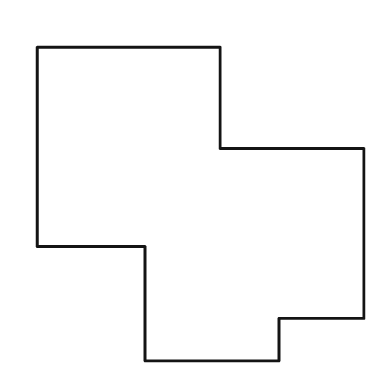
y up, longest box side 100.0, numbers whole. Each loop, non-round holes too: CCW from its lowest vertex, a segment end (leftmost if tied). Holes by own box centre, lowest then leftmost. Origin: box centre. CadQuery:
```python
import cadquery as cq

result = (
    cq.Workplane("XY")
    .moveTo(-17.0, -48.0)
    .lineTo(24.0, -48.0)
    .lineTo(24.0, -35.0)
    .lineTo(50.0, -35.0)
    .lineTo(50.0, 17.0)
    .lineTo(6.0, 17.0)
    .lineTo(6.0, 48.0)
    .lineTo(-50.0, 48.0)
    .lineTo(-50.0, -13.0)
    .lineTo(-17.0, -13.0)
    .close()
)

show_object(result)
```